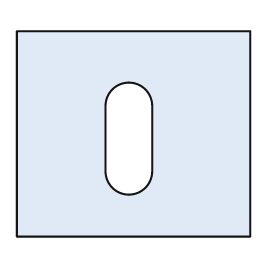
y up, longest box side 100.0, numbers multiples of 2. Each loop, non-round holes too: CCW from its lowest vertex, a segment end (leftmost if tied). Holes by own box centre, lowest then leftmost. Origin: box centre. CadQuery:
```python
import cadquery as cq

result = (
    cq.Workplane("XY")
    .moveTo(-50.0, -44.0)
    .lineTo(50.0, -44.0)
    .lineTo(50.0, 44.0)
    .lineTo(-50.0, 44.0)
    .close()
    .moveTo(-12.0, -16.0)
    .threePointArc((-2.0, -26.0), (8.0, -16.0))
    .lineTo(8.0, 12.0)
    .threePointArc((-2.0, 22.0), (-12.0, 12.0))
    .close()
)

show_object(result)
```